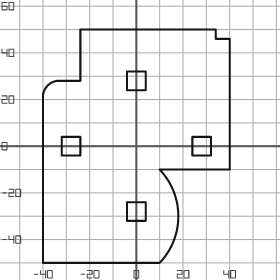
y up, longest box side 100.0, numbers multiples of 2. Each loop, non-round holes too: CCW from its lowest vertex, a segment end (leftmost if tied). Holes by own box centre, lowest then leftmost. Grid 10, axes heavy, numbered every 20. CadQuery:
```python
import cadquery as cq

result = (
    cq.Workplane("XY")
    .moveTo(-40.0, -50.0)
    .lineTo(10.0, -50.0)
    .threePointArc((18.0, -30.0), (10.0, -10.0))
    .lineTo(40.0, -10.0)
    .lineTo(40.0, 46.0)
    .lineTo(34.0, 46.0)
    .lineTo(34.0, 50.0)
    .lineTo(-24.0, 50.0)
    .lineTo(-24.0, 28.0)
    .lineTo(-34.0, 28.0)
    .threePointArc((-38.0, 26.0), (-40.0, 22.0))
    .close()
    .moveTo(-4.0, -32.0)
    .lineTo(4.0, -32.0)
    .lineTo(4.0, -24.0)
    .lineTo(-4.0, -24.0)
    .close()
    .moveTo(-32.0, -4.0)
    .lineTo(-24.0, -4.0)
    .lineTo(-24.0, 4.0)
    .lineTo(-32.0, 4.0)
    .close()
    .moveTo(24.0, -4.0)
    .lineTo(32.0, -4.0)
    .lineTo(32.0, 4.0)
    .lineTo(24.0, 4.0)
    .close()
    .moveTo(-4.0, 24.0)
    .lineTo(4.0, 24.0)
    .lineTo(4.0, 32.0)
    .lineTo(-4.0, 32.0)
    .close()
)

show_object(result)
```